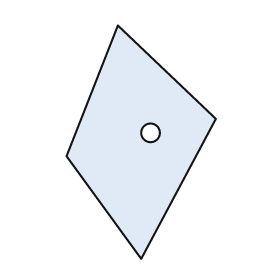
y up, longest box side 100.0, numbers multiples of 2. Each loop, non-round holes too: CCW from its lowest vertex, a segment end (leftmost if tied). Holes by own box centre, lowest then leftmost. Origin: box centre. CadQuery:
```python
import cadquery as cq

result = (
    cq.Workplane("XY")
    .moveTo(0.0, -50.0)
    .lineTo(32.0, 10.0)
    .lineTo(-10.0, 50.0)
    .lineTo(-32.0, -6.0)
    .close()
    .moveTo(4.0, 4.0)
    .circle(4.0)
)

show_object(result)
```